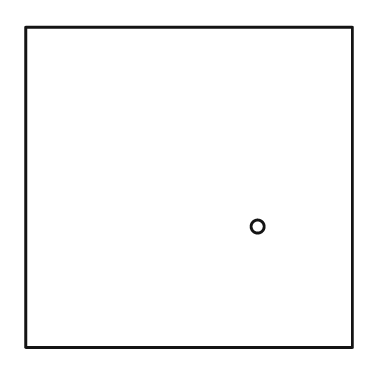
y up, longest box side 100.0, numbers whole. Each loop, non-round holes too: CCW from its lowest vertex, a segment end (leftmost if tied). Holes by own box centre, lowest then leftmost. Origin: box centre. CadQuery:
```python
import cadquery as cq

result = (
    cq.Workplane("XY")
    .moveTo(-50.0, -49.0)
    .lineTo(50.0, -49.0)
    .lineTo(50.0, 49.0)
    .lineTo(-50.0, 49.0)
    .close()
    .moveTo(21.0, -12.0)
    .circle(2.0)
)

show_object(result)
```